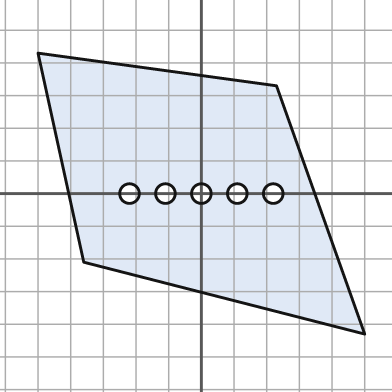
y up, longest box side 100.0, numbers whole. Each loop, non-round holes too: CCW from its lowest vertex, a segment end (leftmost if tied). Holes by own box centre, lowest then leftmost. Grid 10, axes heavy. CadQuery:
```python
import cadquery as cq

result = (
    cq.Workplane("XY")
    .moveTo(50.0, -43.0)
    .lineTo(23.0, 33.0)
    .lineTo(-50.0, 43.0)
    .lineTo(-36.0, -21.0)
    .close()
    .moveTo(-22.0, 0.0)
    .circle(3.0)
    .moveTo(-11.0, 0.0)
    .circle(3.0)
    .moveTo(0.0, 0.0)
    .circle(3.0)
    .moveTo(11.0, 0.0)
    .circle(3.0)
    .moveTo(22.0, 0.0)
    .circle(3.0)
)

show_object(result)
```